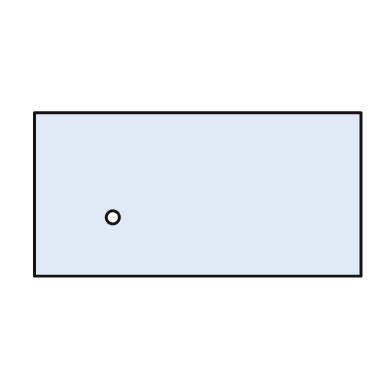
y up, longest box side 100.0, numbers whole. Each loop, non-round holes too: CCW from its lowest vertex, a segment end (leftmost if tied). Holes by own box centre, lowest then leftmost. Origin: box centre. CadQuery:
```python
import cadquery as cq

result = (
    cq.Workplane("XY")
    .moveTo(-50.0, -25.0)
    .lineTo(50.0, -25.0)
    .lineTo(50.0, 25.0)
    .lineTo(-50.0, 25.0)
    .close()
    .moveTo(-26.0, -7.0)
    .circle(2.0)
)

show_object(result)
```